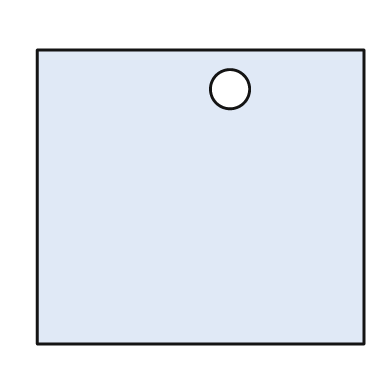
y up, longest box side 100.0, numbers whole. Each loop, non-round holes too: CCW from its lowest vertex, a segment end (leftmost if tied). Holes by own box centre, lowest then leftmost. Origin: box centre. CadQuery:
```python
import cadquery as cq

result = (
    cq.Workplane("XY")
    .moveTo(-50.0, -45.0)
    .lineTo(50.0, -45.0)
    .lineTo(50.0, 45.0)
    .lineTo(-50.0, 45.0)
    .close()
    .moveTo(9.0, 33.0)
    .circle(6.0)
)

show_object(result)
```